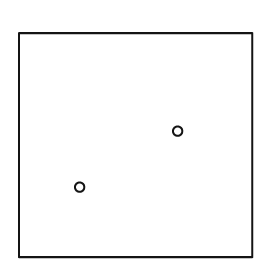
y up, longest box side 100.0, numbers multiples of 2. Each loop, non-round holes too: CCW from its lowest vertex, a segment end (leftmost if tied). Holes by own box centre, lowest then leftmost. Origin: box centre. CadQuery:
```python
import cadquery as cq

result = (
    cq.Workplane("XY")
    .moveTo(-50.0, -48.0)
    .lineTo(50.0, -48.0)
    .lineTo(50.0, 48.0)
    .lineTo(-50.0, 48.0)
    .close()
    .moveTo(-24.0, -18.0)
    .circle(2.0)
    .moveTo(18.0, 6.0)
    .circle(2.0)
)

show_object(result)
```